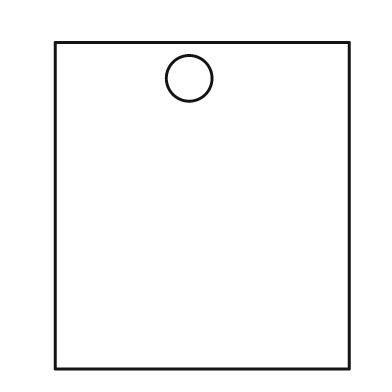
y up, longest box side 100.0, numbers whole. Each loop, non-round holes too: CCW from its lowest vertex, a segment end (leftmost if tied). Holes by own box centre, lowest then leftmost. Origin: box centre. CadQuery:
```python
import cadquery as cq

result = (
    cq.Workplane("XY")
    .moveTo(-45.0, -50.0)
    .lineTo(45.0, -50.0)
    .lineTo(45.0, 50.0)
    .lineTo(-45.0, 50.0)
    .close()
    .moveTo(-4.0, 39.0)
    .circle(7.0)
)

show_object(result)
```